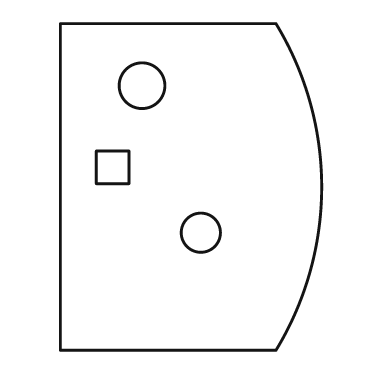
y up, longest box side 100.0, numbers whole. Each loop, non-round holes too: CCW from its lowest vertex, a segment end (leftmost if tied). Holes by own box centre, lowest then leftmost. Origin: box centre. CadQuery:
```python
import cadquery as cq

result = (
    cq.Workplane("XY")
    .moveTo(-40.0, -50.0)
    .lineTo(26.0, -50.0)
    .threePointArc((40.0, 0.0), (26.0, 50.0))
    .lineTo(-40.0, 50.0)
    .close()
    .moveTo(3.0, -14.0)
    .circle(6.0)
    .moveTo(-29.0, 1.0)
    .lineTo(-19.0, 1.0)
    .lineTo(-19.0, 11.0)
    .lineTo(-29.0, 11.0)
    .close()
    .moveTo(-15.0, 31.0)
    .circle(7.0)
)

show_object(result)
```